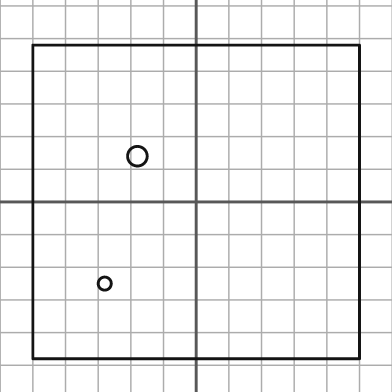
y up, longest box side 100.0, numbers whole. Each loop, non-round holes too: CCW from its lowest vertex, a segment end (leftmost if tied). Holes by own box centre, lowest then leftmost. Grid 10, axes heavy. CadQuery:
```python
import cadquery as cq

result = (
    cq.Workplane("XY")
    .moveTo(-50.0, -48.0)
    .lineTo(50.0, -48.0)
    .lineTo(50.0, 48.0)
    .lineTo(-50.0, 48.0)
    .close()
    .moveTo(-28.0, -25.0)
    .circle(2.0)
    .moveTo(-18.0, 14.0)
    .circle(3.0)
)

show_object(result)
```